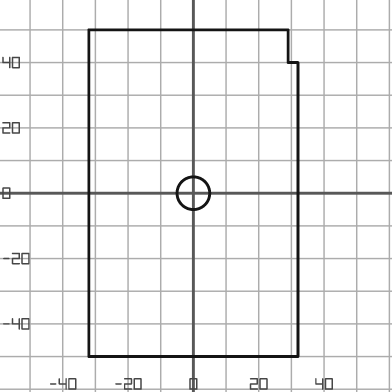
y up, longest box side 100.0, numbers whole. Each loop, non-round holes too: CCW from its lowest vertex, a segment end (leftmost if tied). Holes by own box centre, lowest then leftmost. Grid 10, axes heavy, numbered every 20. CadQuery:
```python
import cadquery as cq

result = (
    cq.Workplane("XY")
    .moveTo(-32.0, -50.0)
    .lineTo(32.0, -50.0)
    .lineTo(32.0, 40.0)
    .lineTo(29.0, 40.0)
    .lineTo(29.0, 50.0)
    .lineTo(-32.0, 50.0)
    .close()
    .moveTo(0.0, 0.0)
    .circle(5.0)
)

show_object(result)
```